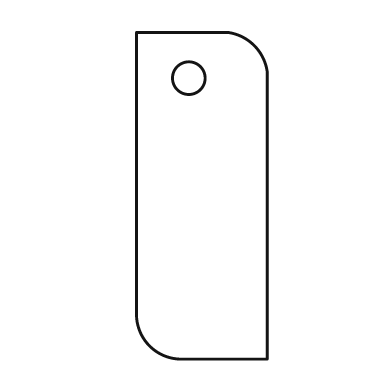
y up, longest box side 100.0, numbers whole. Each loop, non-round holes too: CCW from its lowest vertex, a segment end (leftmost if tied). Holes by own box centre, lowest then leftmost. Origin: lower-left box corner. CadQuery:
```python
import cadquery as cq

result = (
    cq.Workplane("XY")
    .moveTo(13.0, 0.0)
    .lineTo(40.0, 0.0)
    .lineTo(40.0, 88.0)
    .threePointArc((36.0, 96.0), (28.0, 100.0))
    .lineTo(0.0, 100.0)
    .lineTo(0.0, 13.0)
    .threePointArc((4.0, 4.0), (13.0, 0.0))
    .close()
    .moveTo(16.0, 86.0)
    .circle(5.0)
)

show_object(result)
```